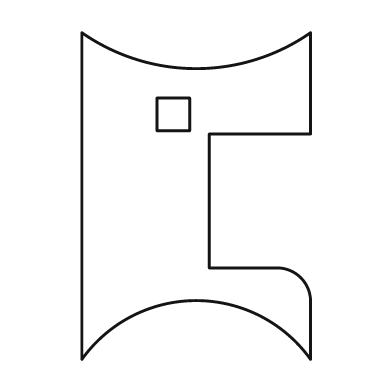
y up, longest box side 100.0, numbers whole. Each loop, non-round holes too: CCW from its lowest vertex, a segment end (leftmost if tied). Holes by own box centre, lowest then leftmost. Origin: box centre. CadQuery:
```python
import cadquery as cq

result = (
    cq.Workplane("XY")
    .moveTo(-35.0, -50.0)
    .threePointArc((0.0, -32.0), (35.0, -50.0))
    .lineTo(35.0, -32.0)
    .threePointArc((32.0, -25.0), (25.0, -22.0))
    .lineTo(4.0, -22.0)
    .lineTo(4.0, 19.0)
    .lineTo(35.0, 19.0)
    .lineTo(35.0, 50.0)
    .threePointArc((0.0, 39.0), (-35.0, 50.0))
    .close()
    .moveTo(-12.0, 20.0)
    .lineTo(-2.0, 20.0)
    .lineTo(-2.0, 30.0)
    .lineTo(-12.0, 30.0)
    .close()
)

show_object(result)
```